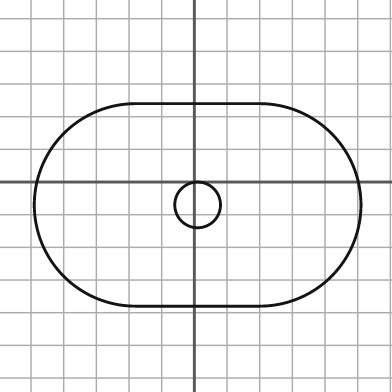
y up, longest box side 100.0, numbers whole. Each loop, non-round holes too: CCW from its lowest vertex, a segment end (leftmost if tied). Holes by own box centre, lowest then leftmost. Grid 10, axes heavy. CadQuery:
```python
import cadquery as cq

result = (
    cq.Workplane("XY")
    .moveTo(-18.0, -38.0)
    .lineTo(20.0, -38.0)
    .threePointArc((51.0, -7.0), (20.0, 24.0))
    .lineTo(-18.0, 24.0)
    .threePointArc((-49.0, -7.0), (-18.0, -38.0))
    .close()
    .moveTo(1.0, -7.0)
    .circle(7.0)
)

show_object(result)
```